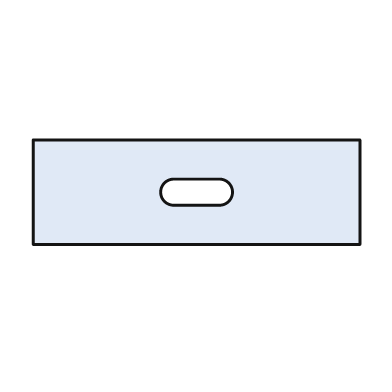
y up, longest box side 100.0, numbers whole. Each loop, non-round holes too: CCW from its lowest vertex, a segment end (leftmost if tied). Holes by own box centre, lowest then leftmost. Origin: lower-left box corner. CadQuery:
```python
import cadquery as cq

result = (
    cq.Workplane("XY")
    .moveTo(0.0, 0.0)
    .lineTo(100.0, 0.0)
    .lineTo(100.0, 32.0)
    .lineTo(0.0, 32.0)
    .close()
    .moveTo(43.0, 12.0)
    .lineTo(57.0, 12.0)
    .threePointArc((61.0, 16.0), (57.0, 20.0))
    .lineTo(43.0, 20.0)
    .threePointArc((39.0, 16.0), (43.0, 12.0))
    .close()
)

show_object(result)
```